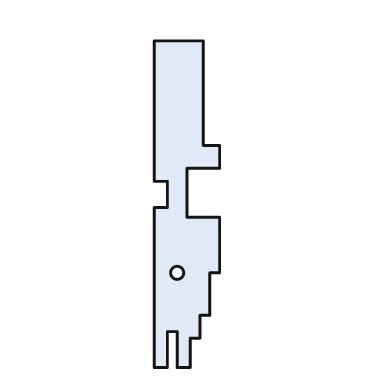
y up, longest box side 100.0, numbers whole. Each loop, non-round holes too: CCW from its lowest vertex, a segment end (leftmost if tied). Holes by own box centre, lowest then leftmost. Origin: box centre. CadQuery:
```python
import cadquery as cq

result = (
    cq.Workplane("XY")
    .moveTo(-10.0, -50.0)
    .lineTo(-6.0, -50.0)
    .lineTo(-6.0, -39.0)
    .lineTo(-3.0, -39.0)
    .lineTo(-3.0, -50.0)
    .lineTo(1.0, -50.0)
    .lineTo(1.0, -41.0)
    .lineTo(4.0, -41.0)
    .lineTo(4.0, -34.0)
    .lineTo(7.0, -34.0)
    .lineTo(7.0, -21.0)
    .lineTo(10.0, -21.0)
    .lineTo(10.0, -4.0)
    .lineTo(0.0, -4.0)
    .lineTo(0.0, 11.0)
    .lineTo(10.0, 11.0)
    .lineTo(10.0, 18.0)
    .lineTo(5.0, 18.0)
    .lineTo(5.0, 50.0)
    .lineTo(-10.0, 50.0)
    .lineTo(-10.0, 7.0)
    .lineTo(-6.0, 7.0)
    .lineTo(-6.0, -1.0)
    .lineTo(-10.0, -1.0)
    .close()
    .moveTo(-3.0, -21.0)
    .circle(2.0)
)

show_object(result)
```